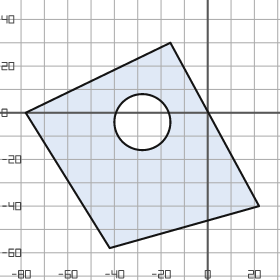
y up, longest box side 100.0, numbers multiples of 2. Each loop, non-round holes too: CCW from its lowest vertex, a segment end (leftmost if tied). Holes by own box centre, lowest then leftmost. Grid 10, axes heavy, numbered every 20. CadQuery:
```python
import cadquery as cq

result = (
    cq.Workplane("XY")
    .moveTo(-42.0, -58.0)
    .lineTo(22.0, -40.0)
    .lineTo(-16.0, 30.0)
    .lineTo(-78.0, 0.0)
    .close()
    .moveTo(-28.0, -4.0)
    .circle(12.0)
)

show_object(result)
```